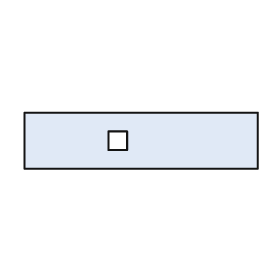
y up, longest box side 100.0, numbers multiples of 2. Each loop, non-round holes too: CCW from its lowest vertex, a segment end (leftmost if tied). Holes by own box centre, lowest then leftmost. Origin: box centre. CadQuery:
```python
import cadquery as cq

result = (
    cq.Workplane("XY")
    .moveTo(-50.0, -12.0)
    .lineTo(50.0, -12.0)
    .lineTo(50.0, 12.0)
    .lineTo(-50.0, 12.0)
    .close()
    .moveTo(-14.0, -4.0)
    .lineTo(-6.0, -4.0)
    .lineTo(-6.0, 4.0)
    .lineTo(-14.0, 4.0)
    .close()
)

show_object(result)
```